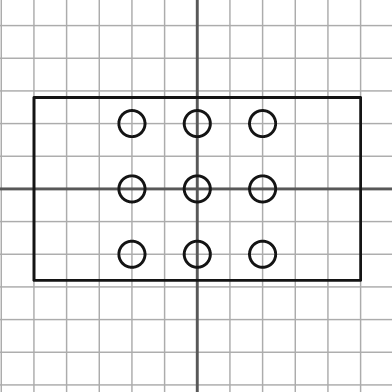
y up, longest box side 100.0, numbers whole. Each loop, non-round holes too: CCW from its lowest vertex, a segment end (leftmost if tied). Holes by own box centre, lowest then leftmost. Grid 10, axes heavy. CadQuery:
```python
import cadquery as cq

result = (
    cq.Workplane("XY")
    .moveTo(-50.0, -28.0)
    .lineTo(50.0, -28.0)
    .lineTo(50.0, 28.0)
    .lineTo(-50.0, 28.0)
    .close()
    .moveTo(-20.0, -20.0)
    .circle(4.0)
    .moveTo(0.0, -20.0)
    .circle(4.0)
    .moveTo(20.0, -20.0)
    .circle(4.0)
    .moveTo(-20.0, 0.0)
    .circle(4.0)
    .moveTo(0.0, 0.0)
    .circle(4.0)
    .moveTo(20.0, 0.0)
    .circle(4.0)
    .moveTo(-20.0, 20.0)
    .circle(4.0)
    .moveTo(0.0, 20.0)
    .circle(4.0)
    .moveTo(20.0, 20.0)
    .circle(4.0)
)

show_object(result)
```